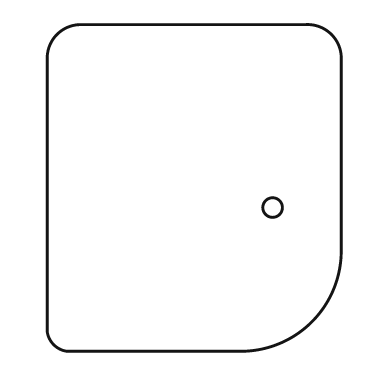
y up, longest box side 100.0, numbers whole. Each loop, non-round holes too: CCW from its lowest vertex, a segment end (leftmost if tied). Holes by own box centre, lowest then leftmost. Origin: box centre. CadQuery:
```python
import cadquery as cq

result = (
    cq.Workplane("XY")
    .moveTo(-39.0, -50.0)
    .lineTo(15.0, -50.0)
    .threePointArc((36.0, -41.0), (45.0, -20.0))
    .lineTo(45.0, 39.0)
    .threePointArc((42.0, 47.0), (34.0, 50.0))
    .lineTo(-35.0, 50.0)
    .threePointArc((-42.0, 47.0), (-45.0, 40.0))
    .lineTo(-45.0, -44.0)
    .threePointArc((-43.0, -48.0), (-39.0, -50.0))
    .close()
    .moveTo(24.0, -6.0)
    .circle(3.0)
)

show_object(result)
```